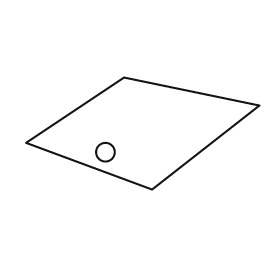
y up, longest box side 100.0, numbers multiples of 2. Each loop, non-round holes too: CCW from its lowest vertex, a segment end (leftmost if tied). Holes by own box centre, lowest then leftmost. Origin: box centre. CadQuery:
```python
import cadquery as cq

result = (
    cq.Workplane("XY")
    .moveTo(4.0, -24.0)
    .lineTo(50.0, 12.0)
    .lineTo(-8.0, 24.0)
    .lineTo(-50.0, -4.0)
    .close()
    .moveTo(-16.0, -8.0)
    .circle(4.0)
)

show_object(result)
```